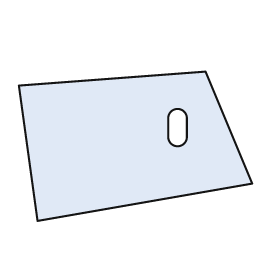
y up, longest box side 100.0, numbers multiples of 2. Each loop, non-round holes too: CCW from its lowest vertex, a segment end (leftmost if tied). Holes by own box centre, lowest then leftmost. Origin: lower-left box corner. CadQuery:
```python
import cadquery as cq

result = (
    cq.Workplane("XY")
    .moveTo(8.0, 0.0)
    .lineTo(100.0, 16.0)
    .lineTo(80.0, 64.0)
    .lineTo(0.0, 58.0)
    .close()
    .moveTo(64.0, 36.0)
    .threePointArc((68.0, 32.0), (72.0, 36.0))
    .lineTo(72.0, 44.0)
    .threePointArc((68.0, 48.0), (64.0, 44.0))
    .close()
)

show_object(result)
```